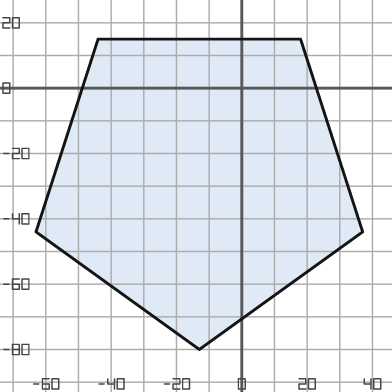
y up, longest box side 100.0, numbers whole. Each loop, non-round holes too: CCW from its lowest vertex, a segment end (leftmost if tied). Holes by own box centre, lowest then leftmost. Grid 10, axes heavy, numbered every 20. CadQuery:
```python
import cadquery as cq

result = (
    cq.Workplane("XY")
    .moveTo(-13.0, -80.0)
    .lineTo(37.0, -44.0)
    .lineTo(18.0, 15.0)
    .lineTo(-44.0, 15.0)
    .lineTo(-63.0, -44.0)
    .close()
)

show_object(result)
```